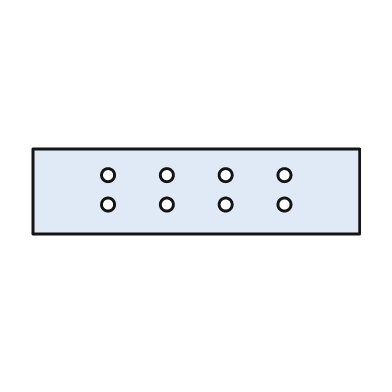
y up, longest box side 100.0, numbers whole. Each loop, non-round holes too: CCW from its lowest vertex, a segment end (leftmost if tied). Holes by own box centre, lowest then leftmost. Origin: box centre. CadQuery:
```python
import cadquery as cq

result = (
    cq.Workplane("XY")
    .moveTo(-50.0, -13.0)
    .lineTo(50.0, -13.0)
    .lineTo(50.0, 13.0)
    .lineTo(-50.0, 13.0)
    .close()
    .moveTo(-27.0, -4.0)
    .circle(2.0)
    .moveTo(-9.0, -4.0)
    .circle(2.0)
    .moveTo(9.0, -4.0)
    .circle(2.0)
    .moveTo(27.0, -4.0)
    .circle(2.0)
    .moveTo(-27.0, 5.0)
    .circle(2.0)
    .moveTo(-9.0, 5.0)
    .circle(2.0)
    .moveTo(9.0, 5.0)
    .circle(2.0)
    .moveTo(27.0, 5.0)
    .circle(2.0)
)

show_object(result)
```